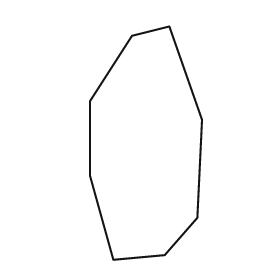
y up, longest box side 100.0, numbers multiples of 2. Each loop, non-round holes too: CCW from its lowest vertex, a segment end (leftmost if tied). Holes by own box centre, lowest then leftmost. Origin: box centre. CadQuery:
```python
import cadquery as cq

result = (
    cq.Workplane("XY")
    .moveTo(-14.0, -50.0)
    .lineTo(8.0, -48.0)
    .lineTo(22.0, -32.0)
    .lineTo(24.0, 10.0)
    .lineTo(10.0, 50.0)
    .lineTo(-6.0, 46.0)
    .lineTo(-24.0, 18.0)
    .lineTo(-24.0, -14.0)
    .close()
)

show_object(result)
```